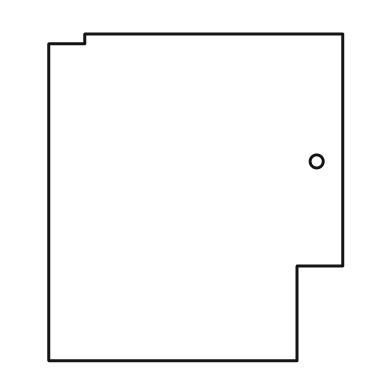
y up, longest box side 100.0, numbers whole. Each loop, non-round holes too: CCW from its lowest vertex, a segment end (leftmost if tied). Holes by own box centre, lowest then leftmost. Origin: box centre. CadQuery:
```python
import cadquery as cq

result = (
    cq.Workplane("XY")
    .moveTo(-45.0, -50.0)
    .lineTo(31.0, -50.0)
    .lineTo(31.0, -21.0)
    .lineTo(45.0, -21.0)
    .lineTo(45.0, 50.0)
    .lineTo(-34.0, 50.0)
    .lineTo(-34.0, 47.0)
    .lineTo(-45.0, 47.0)
    .close()
    .moveTo(37.0, 11.0)
    .circle(2.0)
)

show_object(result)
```